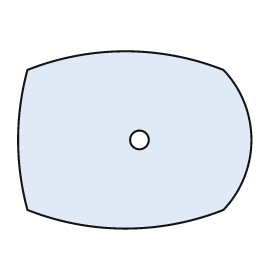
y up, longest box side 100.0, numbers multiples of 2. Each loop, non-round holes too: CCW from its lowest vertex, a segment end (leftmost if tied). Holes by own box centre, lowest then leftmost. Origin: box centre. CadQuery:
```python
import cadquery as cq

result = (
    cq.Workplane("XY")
    .moveTo(-46.0, -30.0)
    .threePointArc((-4.0, -38.0), (38.0, -30.0))
    .threePointArc((50.0, 0.0), (38.0, 30.0))
    .threePointArc((-4.0, 38.0), (-46.0, 30.0))
    .threePointArc((-50.0, 0.0), (-46.0, -30.0))
    .close()
    .moveTo(2.0, 0.0)
    .circle(4.0)
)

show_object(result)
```